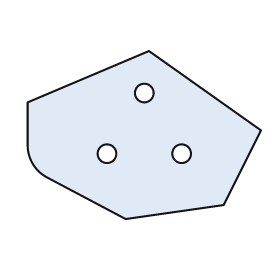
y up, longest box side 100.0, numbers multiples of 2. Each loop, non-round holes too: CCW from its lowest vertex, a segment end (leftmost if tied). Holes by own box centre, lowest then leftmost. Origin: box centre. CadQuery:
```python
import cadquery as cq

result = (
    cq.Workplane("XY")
    .moveTo(-8.0, -36.0)
    .lineTo(34.0, -30.0)
    .lineTo(50.0, 2.0)
    .lineTo(2.0, 36.0)
    .lineTo(-50.0, 14.0)
    .lineTo(-50.0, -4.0)
    .threePointArc((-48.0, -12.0), (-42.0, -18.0))
    .close()
    .moveTo(-16.0, -8.0)
    .circle(4.0)
    .moveTo(16.0, -8.0)
    .circle(4.0)
    .moveTo(0.0, 18.0)
    .circle(4.0)
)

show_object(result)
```